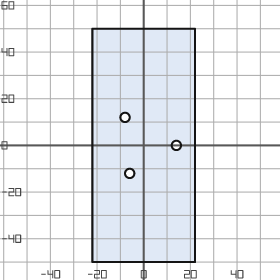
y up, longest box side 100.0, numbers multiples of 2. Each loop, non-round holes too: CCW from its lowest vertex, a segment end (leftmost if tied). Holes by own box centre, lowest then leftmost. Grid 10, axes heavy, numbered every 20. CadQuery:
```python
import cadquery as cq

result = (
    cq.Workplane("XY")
    .moveTo(-22.0, -50.0)
    .lineTo(22.0, -50.0)
    .lineTo(22.0, 50.0)
    .lineTo(-22.0, 50.0)
    .close()
    .moveTo(-6.0, -12.0)
    .circle(2.0)
    .moveTo(14.0, 0.0)
    .circle(2.0)
    .moveTo(-8.0, 12.0)
    .circle(2.0)
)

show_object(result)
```